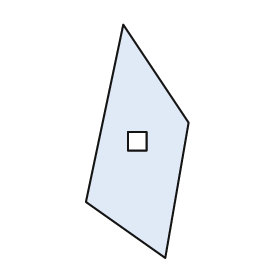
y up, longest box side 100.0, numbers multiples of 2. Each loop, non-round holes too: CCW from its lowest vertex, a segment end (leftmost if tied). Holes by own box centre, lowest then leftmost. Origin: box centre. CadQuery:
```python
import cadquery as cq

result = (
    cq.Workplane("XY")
    .moveTo(12.0, -50.0)
    .lineTo(22.0, 8.0)
    .lineTo(-6.0, 50.0)
    .lineTo(-22.0, -26.0)
    .close()
    .moveTo(-4.0, -4.0)
    .lineTo(4.0, -4.0)
    .lineTo(4.0, 4.0)
    .lineTo(-4.0, 4.0)
    .close()
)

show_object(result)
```